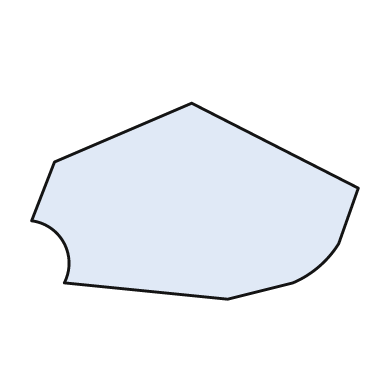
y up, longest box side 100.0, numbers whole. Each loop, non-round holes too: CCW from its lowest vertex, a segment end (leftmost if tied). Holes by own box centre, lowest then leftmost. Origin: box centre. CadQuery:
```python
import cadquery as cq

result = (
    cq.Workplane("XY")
    .moveTo(10.0, -30.0)
    .lineTo(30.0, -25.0)
    .threePointArc((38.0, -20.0), (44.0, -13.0))
    .lineTo(50.0, 4.0)
    .lineTo(-1.0, 30.0)
    .lineTo(-43.0, 12.0)
    .lineTo(-50.0, -6.0)
    .threePointArc((-40.0, -13.0), (-40.0, -25.0))
    .close()
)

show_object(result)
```